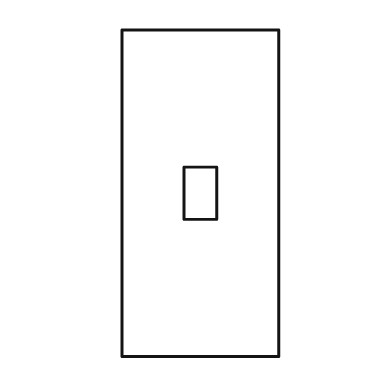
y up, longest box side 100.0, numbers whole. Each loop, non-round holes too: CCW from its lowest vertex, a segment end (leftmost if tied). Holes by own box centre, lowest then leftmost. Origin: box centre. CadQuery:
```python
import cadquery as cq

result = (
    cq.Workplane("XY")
    .moveTo(-24.0, -50.0)
    .lineTo(24.0, -50.0)
    .lineTo(24.0, 50.0)
    .lineTo(-24.0, 50.0)
    .close()
    .moveTo(-5.0, -8.0)
    .lineTo(5.0, -8.0)
    .lineTo(5.0, 8.0)
    .lineTo(-5.0, 8.0)
    .close()
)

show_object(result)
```